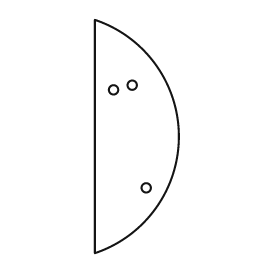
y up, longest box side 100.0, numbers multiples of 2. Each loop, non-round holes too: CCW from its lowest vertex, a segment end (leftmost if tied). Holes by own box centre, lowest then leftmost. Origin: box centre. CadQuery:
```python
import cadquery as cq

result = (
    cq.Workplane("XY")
    .moveTo(-18.0, -50.0)
    .threePointArc((18.0, 0.0), (-18.0, 50.0))
    .close()
    .moveTo(4.0, -22.0)
    .circle(2.0)
    .moveTo(-10.0, 20.0)
    .circle(2.0)
    .moveTo(-2.0, 22.0)
    .circle(2.0)
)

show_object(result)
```